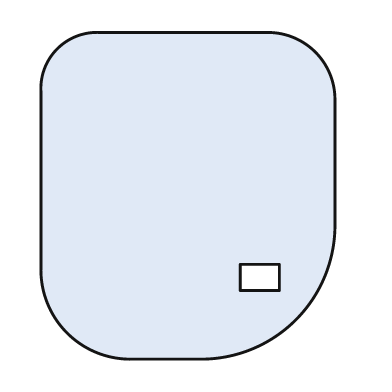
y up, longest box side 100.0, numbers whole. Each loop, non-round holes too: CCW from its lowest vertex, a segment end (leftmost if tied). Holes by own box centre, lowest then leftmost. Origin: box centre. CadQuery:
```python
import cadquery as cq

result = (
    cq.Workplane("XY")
    .moveTo(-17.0, -50.0)
    .lineTo(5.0, -50.0)
    .threePointArc((33.0, -38.0), (45.0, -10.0))
    .lineTo(45.0, 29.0)
    .threePointArc((39.0, 44.0), (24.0, 50.0))
    .lineTo(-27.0, 50.0)
    .threePointArc((-40.0, 45.0), (-45.0, 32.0))
    .lineTo(-45.0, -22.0)
    .threePointArc((-37.0, -42.0), (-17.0, -50.0))
    .close()
    .moveTo(16.0, -29.0)
    .lineTo(28.0, -29.0)
    .lineTo(28.0, -21.0)
    .lineTo(16.0, -21.0)
    .close()
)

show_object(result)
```